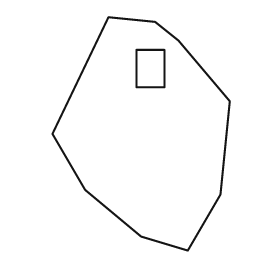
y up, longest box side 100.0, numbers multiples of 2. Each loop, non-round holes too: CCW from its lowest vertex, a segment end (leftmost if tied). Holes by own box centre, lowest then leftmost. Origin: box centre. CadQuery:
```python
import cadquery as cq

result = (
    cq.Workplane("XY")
    .moveTo(20.0, -50.0)
    .lineTo(34.0, -26.0)
    .lineTo(38.0, 14.0)
    .lineTo(16.0, 40.0)
    .lineTo(6.0, 48.0)
    .lineTo(-14.0, 50.0)
    .lineTo(-38.0, 0.0)
    .lineTo(-24.0, -24.0)
    .lineTo(0.0, -44.0)
    .close()
    .moveTo(-2.0, 20.0)
    .lineTo(10.0, 20.0)
    .lineTo(10.0, 36.0)
    .lineTo(-2.0, 36.0)
    .close()
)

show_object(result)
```